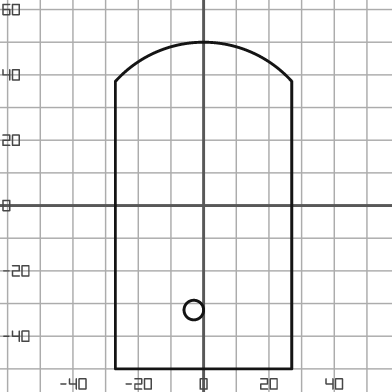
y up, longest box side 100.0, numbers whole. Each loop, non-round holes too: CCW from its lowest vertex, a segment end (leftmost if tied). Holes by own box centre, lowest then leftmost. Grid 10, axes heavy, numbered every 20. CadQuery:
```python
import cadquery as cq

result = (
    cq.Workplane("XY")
    .moveTo(-27.0, -50.0)
    .lineTo(27.0, -50.0)
    .lineTo(27.0, 38.0)
    .threePointArc((0.0, 50.0), (-27.0, 38.0))
    .close()
    .moveTo(-3.0, -32.0)
    .circle(3.0)
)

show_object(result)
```